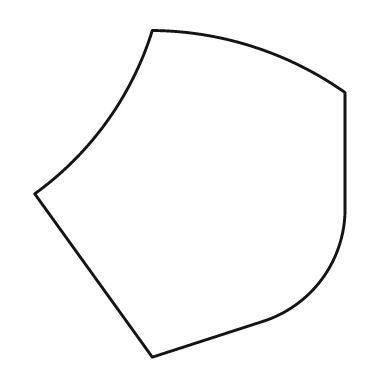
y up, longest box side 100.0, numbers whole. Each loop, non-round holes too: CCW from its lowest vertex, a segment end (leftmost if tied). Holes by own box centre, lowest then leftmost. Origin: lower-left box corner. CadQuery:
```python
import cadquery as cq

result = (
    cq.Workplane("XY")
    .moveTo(36.0, 0.0)
    .lineTo(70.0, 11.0)
    .threePointArc((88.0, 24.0), (95.0, 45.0))
    .lineTo(95.0, 81.0)
    .threePointArc((67.0, 95.0), (36.0, 100.0))
    .threePointArc((22.0, 72.0), (0.0, 50.0))
    .close()
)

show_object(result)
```